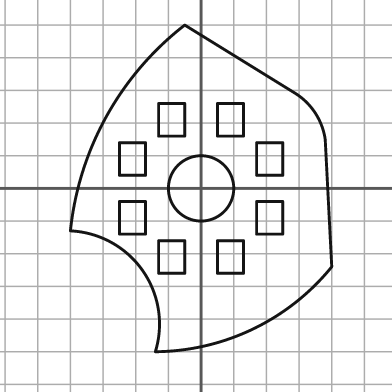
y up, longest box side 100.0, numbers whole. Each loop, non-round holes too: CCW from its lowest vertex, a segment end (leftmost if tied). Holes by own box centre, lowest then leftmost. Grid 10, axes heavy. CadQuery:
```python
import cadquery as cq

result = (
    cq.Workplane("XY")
    .moveTo(-14.0, -50.0)
    .threePointArc((16.0, -43.0), (40.0, -24.0))
    .lineTo(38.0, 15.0)
    .threePointArc((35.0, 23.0), (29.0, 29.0))
    .lineTo(-5.0, 50.0)
    .threePointArc((-29.0, 22.0), (-40.0, -13.0))
    .threePointArc((-18.0, -25.0), (-14.0, -50.0))
    .close()
    .moveTo(-13.0, -26.0)
    .lineTo(-5.0, -26.0)
    .lineTo(-5.0, -16.0)
    .lineTo(-13.0, -16.0)
    .close()
    .moveTo(5.0, -26.0)
    .lineTo(13.0, -26.0)
    .lineTo(13.0, -16.0)
    .lineTo(5.0, -16.0)
    .close()
    .moveTo(-25.0, -14.0)
    .lineTo(-17.0, -14.0)
    .lineTo(-17.0, -4.0)
    .lineTo(-25.0, -4.0)
    .close()
    .moveTo(17.0, -14.0)
    .lineTo(25.0, -14.0)
    .lineTo(25.0, -4.0)
    .lineTo(17.0, -4.0)
    .close()
    .moveTo(0.0, 0.0)
    .circle(10.0)
    .moveTo(-25.0, 4.0)
    .lineTo(-17.0, 4.0)
    .lineTo(-17.0, 14.0)
    .lineTo(-25.0, 14.0)
    .close()
    .moveTo(17.0, 4.0)
    .lineTo(25.0, 4.0)
    .lineTo(25.0, 14.0)
    .lineTo(17.0, 14.0)
    .close()
    .moveTo(-13.0, 16.0)
    .lineTo(-5.0, 16.0)
    .lineTo(-5.0, 26.0)
    .lineTo(-13.0, 26.0)
    .close()
    .moveTo(5.0, 16.0)
    .lineTo(13.0, 16.0)
    .lineTo(13.0, 26.0)
    .lineTo(5.0, 26.0)
    .close()
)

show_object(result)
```